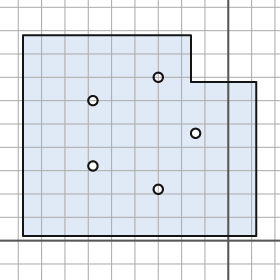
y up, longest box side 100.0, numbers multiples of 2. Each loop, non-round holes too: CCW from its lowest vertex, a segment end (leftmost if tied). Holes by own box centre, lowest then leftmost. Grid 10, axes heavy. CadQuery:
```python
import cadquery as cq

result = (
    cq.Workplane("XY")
    .moveTo(-88.0, 2.0)
    .lineTo(12.0, 2.0)
    .lineTo(12.0, 68.0)
    .lineTo(-16.0, 68.0)
    .lineTo(-16.0, 88.0)
    .lineTo(-88.0, 88.0)
    .close()
    .moveTo(-30.0, 22.0)
    .circle(2.0)
    .moveTo(-58.0, 32.0)
    .circle(2.0)
    .moveTo(-14.0, 46.0)
    .circle(2.0)
    .moveTo(-58.0, 60.0)
    .circle(2.0)
    .moveTo(-30.0, 70.0)
    .circle(2.0)
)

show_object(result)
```